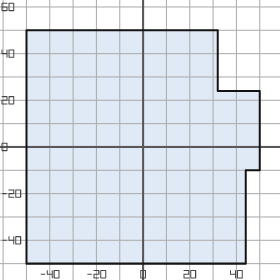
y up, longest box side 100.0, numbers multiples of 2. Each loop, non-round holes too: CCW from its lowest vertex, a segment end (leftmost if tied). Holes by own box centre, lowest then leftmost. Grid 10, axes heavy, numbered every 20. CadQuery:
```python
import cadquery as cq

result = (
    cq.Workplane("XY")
    .moveTo(-50.0, -50.0)
    .lineTo(44.0, -50.0)
    .lineTo(44.0, -10.0)
    .lineTo(50.0, -10.0)
    .lineTo(50.0, 24.0)
    .lineTo(32.0, 24.0)
    .lineTo(32.0, 50.0)
    .lineTo(-50.0, 50.0)
    .close()
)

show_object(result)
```